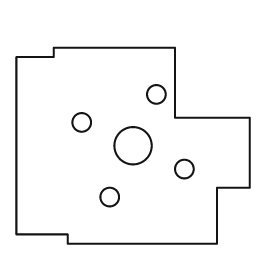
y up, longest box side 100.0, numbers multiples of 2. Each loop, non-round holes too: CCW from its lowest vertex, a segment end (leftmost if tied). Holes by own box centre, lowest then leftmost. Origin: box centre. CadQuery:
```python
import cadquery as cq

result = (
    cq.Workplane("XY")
    .moveTo(-28.0, -42.0)
    .lineTo(36.0, -42.0)
    .lineTo(36.0, -18.0)
    .lineTo(50.0, -18.0)
    .lineTo(50.0, 12.0)
    .lineTo(18.0, 12.0)
    .lineTo(18.0, 42.0)
    .lineTo(-34.0, 42.0)
    .lineTo(-34.0, 38.0)
    .lineTo(-50.0, 38.0)
    .lineTo(-50.0, -38.0)
    .lineTo(-28.0, -38.0)
    .close()
    .moveTo(-10.0, -22.0)
    .circle(4.0)
    .moveTo(22.0, -10.0)
    .circle(4.0)
    .moveTo(0.0, 0.0)
    .circle(8.0)
    .moveTo(-22.0, 10.0)
    .circle(4.0)
    .moveTo(10.0, 22.0)
    .circle(4.0)
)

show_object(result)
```